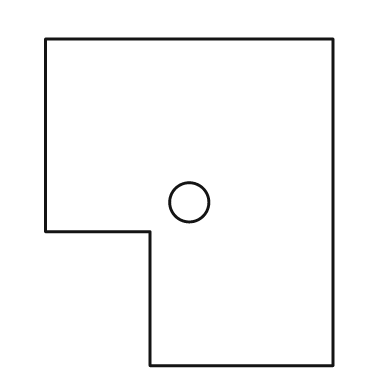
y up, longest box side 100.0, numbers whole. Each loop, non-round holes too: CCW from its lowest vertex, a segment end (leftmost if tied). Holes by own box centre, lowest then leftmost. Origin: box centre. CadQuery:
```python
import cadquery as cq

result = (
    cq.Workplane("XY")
    .moveTo(-12.0, -50.0)
    .lineTo(44.0, -50.0)
    .lineTo(44.0, 50.0)
    .lineTo(-44.0, 50.0)
    .lineTo(-44.0, -9.0)
    .lineTo(-12.0, -9.0)
    .close()
    .moveTo(0.0, 0.0)
    .circle(6.0)
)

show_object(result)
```